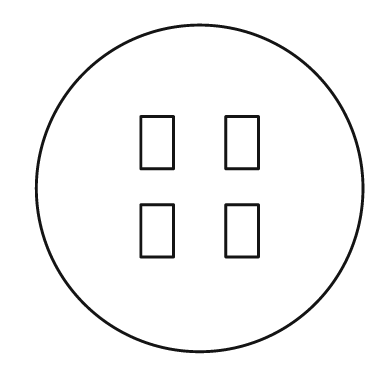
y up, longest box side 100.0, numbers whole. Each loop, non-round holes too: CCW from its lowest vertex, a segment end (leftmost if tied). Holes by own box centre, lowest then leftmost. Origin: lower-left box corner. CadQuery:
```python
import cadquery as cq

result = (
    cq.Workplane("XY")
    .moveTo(50.0, 50.0)
    .circle(50.0)
    .moveTo(32.0, 29.0)
    .lineTo(42.0, 29.0)
    .lineTo(42.0, 45.0)
    .lineTo(32.0, 45.0)
    .close()
    .moveTo(58.0, 29.0)
    .lineTo(68.0, 29.0)
    .lineTo(68.0, 45.0)
    .lineTo(58.0, 45.0)
    .close()
    .moveTo(32.0, 56.0)
    .lineTo(42.0, 56.0)
    .lineTo(42.0, 72.0)
    .lineTo(32.0, 72.0)
    .close()
    .moveTo(58.0, 56.0)
    .lineTo(68.0, 56.0)
    .lineTo(68.0, 72.0)
    .lineTo(58.0, 72.0)
    .close()
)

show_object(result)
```